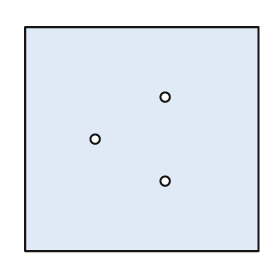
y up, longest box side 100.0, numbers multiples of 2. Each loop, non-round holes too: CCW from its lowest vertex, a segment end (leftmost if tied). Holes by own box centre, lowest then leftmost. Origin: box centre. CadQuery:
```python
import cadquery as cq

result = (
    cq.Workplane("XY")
    .moveTo(-50.0, -48.0)
    .lineTo(50.0, -48.0)
    .lineTo(50.0, 48.0)
    .lineTo(-50.0, 48.0)
    .close()
    .moveTo(10.0, -18.0)
    .circle(2.0)
    .moveTo(-20.0, 0.0)
    .circle(2.0)
    .moveTo(10.0, 18.0)
    .circle(2.0)
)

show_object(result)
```